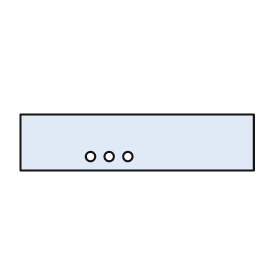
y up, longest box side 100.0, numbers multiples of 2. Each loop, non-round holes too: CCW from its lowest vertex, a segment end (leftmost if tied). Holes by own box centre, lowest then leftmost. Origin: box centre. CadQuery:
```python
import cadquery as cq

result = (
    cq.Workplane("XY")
    .moveTo(-50.0, -12.0)
    .lineTo(50.0, -12.0)
    .lineTo(50.0, 12.0)
    .lineTo(-50.0, 12.0)
    .close()
    .moveTo(-20.0, -6.0)
    .circle(2.0)
    .moveTo(-12.0, -6.0)
    .circle(2.0)
    .moveTo(-4.0, -6.0)
    .circle(2.0)
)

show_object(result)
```